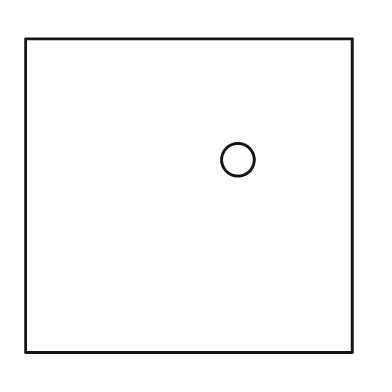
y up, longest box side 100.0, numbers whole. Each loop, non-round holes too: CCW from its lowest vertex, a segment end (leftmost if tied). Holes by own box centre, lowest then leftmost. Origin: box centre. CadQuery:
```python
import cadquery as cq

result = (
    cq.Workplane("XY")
    .moveTo(-50.0, -48.0)
    .lineTo(50.0, -48.0)
    .lineTo(50.0, 48.0)
    .lineTo(-50.0, 48.0)
    .close()
    .moveTo(15.0, 11.0)
    .circle(5.0)
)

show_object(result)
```